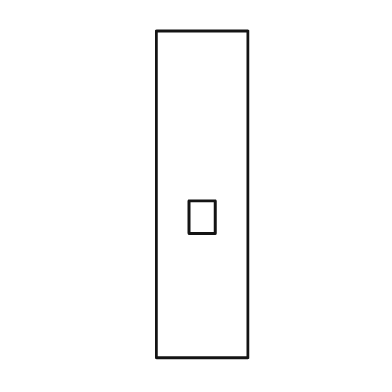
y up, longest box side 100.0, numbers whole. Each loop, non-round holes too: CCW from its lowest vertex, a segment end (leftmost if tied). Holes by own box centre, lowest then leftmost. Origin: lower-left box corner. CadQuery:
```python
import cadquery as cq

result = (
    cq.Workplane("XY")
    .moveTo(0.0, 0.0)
    .lineTo(28.0, 0.0)
    .lineTo(28.0, 100.0)
    .lineTo(0.0, 100.0)
    .close()
    .moveTo(10.0, 38.0)
    .lineTo(18.0, 38.0)
    .lineTo(18.0, 48.0)
    .lineTo(10.0, 48.0)
    .close()
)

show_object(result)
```